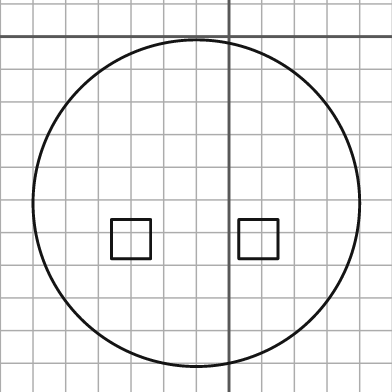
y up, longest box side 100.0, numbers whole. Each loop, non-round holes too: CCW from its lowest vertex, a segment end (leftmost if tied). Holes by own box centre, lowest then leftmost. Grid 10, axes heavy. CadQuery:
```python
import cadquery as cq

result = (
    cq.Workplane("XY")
    .moveTo(-10.0, -51.0)
    .circle(50.0)
    .moveTo(-36.0, -68.0)
    .lineTo(-24.0, -68.0)
    .lineTo(-24.0, -56.0)
    .lineTo(-36.0, -56.0)
    .close()
    .moveTo(3.0, -68.0)
    .lineTo(15.0, -68.0)
    .lineTo(15.0, -56.0)
    .lineTo(3.0, -56.0)
    .close()
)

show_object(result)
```